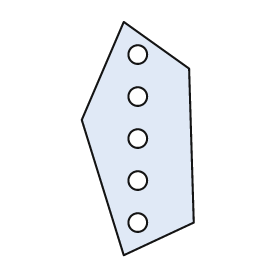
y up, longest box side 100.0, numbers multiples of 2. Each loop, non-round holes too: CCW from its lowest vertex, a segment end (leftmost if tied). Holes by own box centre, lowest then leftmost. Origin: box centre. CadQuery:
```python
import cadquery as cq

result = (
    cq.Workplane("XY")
    .moveTo(-6.0, -50.0)
    .lineTo(24.0, -36.0)
    .lineTo(22.0, 30.0)
    .lineTo(-6.0, 50.0)
    .lineTo(-24.0, 8.0)
    .close()
    .moveTo(0.0, -36.0)
    .circle(4.0)
    .moveTo(0.0, -18.0)
    .circle(4.0)
    .moveTo(0.0, 0.0)
    .circle(4.0)
    .moveTo(0.0, 18.0)
    .circle(4.0)
    .moveTo(0.0, 36.0)
    .circle(4.0)
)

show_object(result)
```